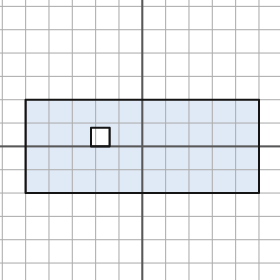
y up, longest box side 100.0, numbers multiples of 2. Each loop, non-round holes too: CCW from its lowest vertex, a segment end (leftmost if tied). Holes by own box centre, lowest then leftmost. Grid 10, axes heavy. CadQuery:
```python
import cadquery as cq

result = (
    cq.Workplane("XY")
    .moveTo(-50.0, -20.0)
    .lineTo(50.0, -20.0)
    .lineTo(50.0, 20.0)
    .lineTo(-50.0, 20.0)
    .close()
    .moveTo(-22.0, 0.0)
    .lineTo(-14.0, 0.0)
    .lineTo(-14.0, 8.0)
    .lineTo(-22.0, 8.0)
    .close()
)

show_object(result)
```